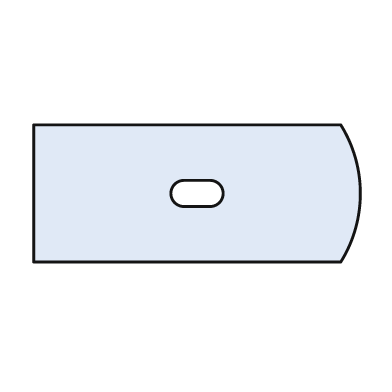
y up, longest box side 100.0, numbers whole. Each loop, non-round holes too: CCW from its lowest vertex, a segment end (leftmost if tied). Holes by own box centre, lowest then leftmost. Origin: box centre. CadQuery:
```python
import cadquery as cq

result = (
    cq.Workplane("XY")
    .moveTo(-50.0, -21.0)
    .lineTo(44.0, -21.0)
    .threePointArc((50.0, 0.0), (44.0, 21.0))
    .lineTo(-50.0, 21.0)
    .close()
    .moveTo(-4.0, -4.0)
    .lineTo(4.0, -4.0)
    .threePointArc((8.0, 0.0), (4.0, 4.0))
    .lineTo(-4.0, 4.0)
    .threePointArc((-8.0, 0.0), (-4.0, -4.0))
    .close()
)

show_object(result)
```